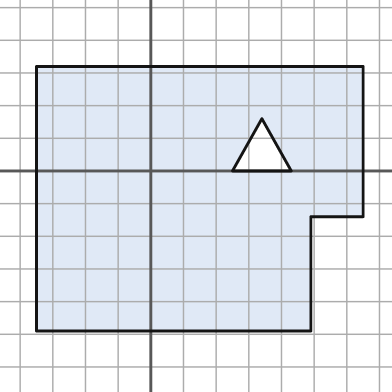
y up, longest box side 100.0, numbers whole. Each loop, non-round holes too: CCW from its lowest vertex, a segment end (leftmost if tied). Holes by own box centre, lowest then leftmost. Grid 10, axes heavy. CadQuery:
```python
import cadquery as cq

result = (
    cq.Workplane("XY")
    .moveTo(-35.0, -49.0)
    .lineTo(49.0, -49.0)
    .lineTo(49.0, -14.0)
    .lineTo(65.0, -14.0)
    .lineTo(65.0, 32.0)
    .lineTo(-35.0, 32.0)
    .close()
    .moveTo(25.0, 0.0)
    .lineTo(43.0, 0.0)
    .lineTo(34.0, 16.0)
    .close()
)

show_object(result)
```